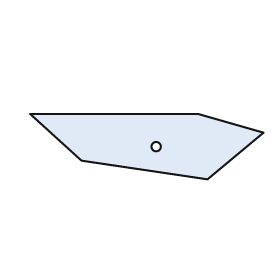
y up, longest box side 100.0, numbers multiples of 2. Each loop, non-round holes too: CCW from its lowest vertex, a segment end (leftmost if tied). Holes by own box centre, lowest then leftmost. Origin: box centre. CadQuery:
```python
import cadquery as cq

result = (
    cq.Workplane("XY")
    .moveTo(26.0, -14.0)
    .lineTo(50.0, 6.0)
    .lineTo(22.0, 14.0)
    .lineTo(-50.0, 14.0)
    .lineTo(-28.0, -6.0)
    .close()
    .moveTo(4.0, 0.0)
    .circle(2.0)
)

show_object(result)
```